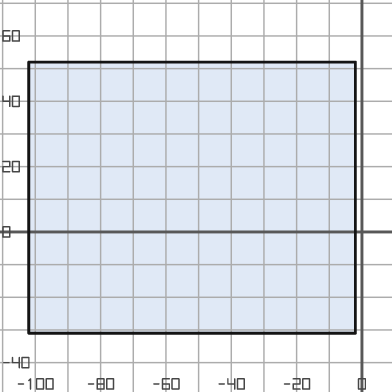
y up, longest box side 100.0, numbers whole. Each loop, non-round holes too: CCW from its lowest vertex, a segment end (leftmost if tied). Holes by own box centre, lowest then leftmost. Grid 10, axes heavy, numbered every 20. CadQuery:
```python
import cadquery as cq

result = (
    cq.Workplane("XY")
    .moveTo(-102.0, -31.0)
    .lineTo(-2.0, -31.0)
    .lineTo(-2.0, 52.0)
    .lineTo(-102.0, 52.0)
    .close()
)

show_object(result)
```